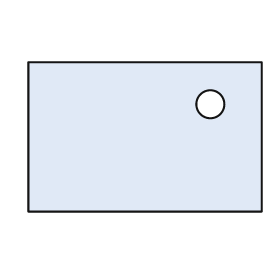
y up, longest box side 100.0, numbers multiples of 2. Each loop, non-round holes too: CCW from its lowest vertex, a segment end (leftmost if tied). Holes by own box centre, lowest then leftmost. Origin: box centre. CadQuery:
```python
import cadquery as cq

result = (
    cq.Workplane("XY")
    .moveTo(-50.0, -32.0)
    .lineTo(50.0, -32.0)
    .lineTo(50.0, 32.0)
    .lineTo(-50.0, 32.0)
    .close()
    .moveTo(28.0, 14.0)
    .circle(6.0)
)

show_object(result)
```